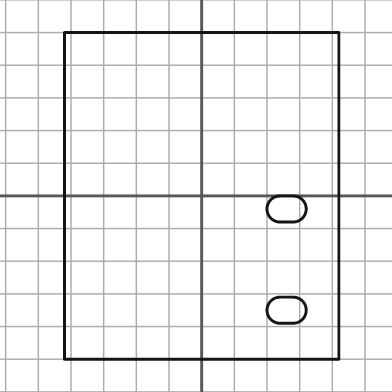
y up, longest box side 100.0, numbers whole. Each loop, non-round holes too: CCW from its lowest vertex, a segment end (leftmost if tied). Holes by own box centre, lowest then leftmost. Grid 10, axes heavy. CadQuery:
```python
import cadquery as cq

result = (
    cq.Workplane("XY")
    .moveTo(-42.0, -50.0)
    .lineTo(42.0, -50.0)
    .lineTo(42.0, 50.0)
    .lineTo(-42.0, 50.0)
    .close()
    .moveTo(24.0, -39.0)
    .lineTo(28.0, -39.0)
    .threePointArc((32.0, -35.0), (28.0, -31.0))
    .lineTo(24.0, -31.0)
    .threePointArc((20.0, -35.0), (24.0, -39.0))
    .close()
    .moveTo(24.0, -8.0)
    .lineTo(28.0, -8.0)
    .threePointArc((32.0, -4.0), (28.0, 0.0))
    .lineTo(24.0, 0.0)
    .threePointArc((20.0, -4.0), (24.0, -8.0))
    .close()
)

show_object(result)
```